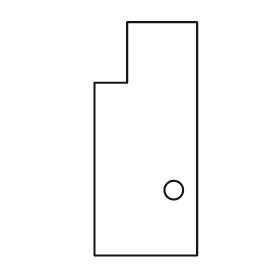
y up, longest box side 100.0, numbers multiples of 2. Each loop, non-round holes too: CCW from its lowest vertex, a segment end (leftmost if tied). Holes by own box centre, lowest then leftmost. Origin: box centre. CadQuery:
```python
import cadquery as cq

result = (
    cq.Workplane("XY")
    .moveTo(-22.0, -50.0)
    .lineTo(22.0, -50.0)
    .lineTo(22.0, 50.0)
    .lineTo(-8.0, 50.0)
    .lineTo(-8.0, 24.0)
    .lineTo(-22.0, 24.0)
    .close()
    .moveTo(12.0, -22.0)
    .circle(4.0)
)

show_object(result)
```